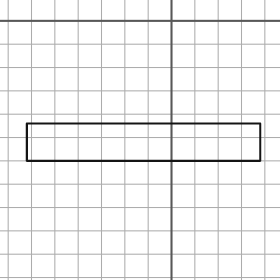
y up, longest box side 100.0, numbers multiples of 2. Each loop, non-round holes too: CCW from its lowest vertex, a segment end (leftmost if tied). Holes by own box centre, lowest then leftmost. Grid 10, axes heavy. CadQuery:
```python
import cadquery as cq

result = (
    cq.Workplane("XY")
    .moveTo(-62.0, -60.0)
    .lineTo(38.0, -60.0)
    .lineTo(38.0, -44.0)
    .lineTo(-62.0, -44.0)
    .close()
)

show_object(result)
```